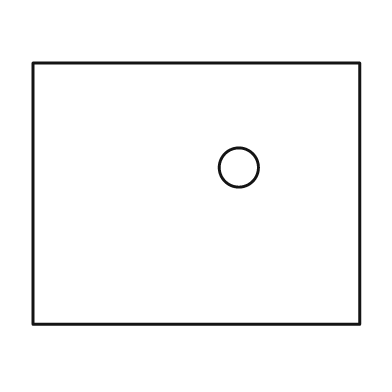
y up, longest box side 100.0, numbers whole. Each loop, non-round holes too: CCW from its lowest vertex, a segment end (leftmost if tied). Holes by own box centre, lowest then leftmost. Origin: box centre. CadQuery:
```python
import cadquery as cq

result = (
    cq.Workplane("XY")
    .moveTo(-50.0, -40.0)
    .lineTo(50.0, -40.0)
    .lineTo(50.0, 40.0)
    .lineTo(-50.0, 40.0)
    .close()
    .moveTo(13.0, 8.0)
    .circle(6.0)
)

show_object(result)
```